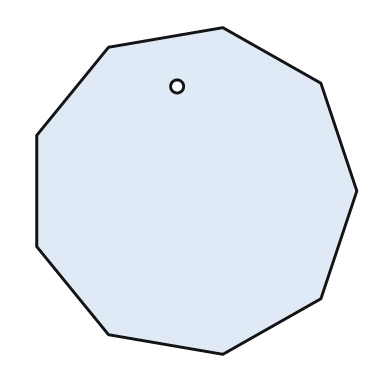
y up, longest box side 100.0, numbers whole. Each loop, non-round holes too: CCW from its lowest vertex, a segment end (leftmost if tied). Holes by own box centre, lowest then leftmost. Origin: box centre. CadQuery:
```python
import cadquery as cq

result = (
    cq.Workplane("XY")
    .moveTo(8.0, -50.0)
    .lineTo(38.0, -33.0)
    .lineTo(49.0, 0.0)
    .lineTo(38.0, 33.0)
    .lineTo(8.0, 50.0)
    .lineTo(-27.0, 44.0)
    .lineTo(-49.0, 17.0)
    .lineTo(-49.0, -17.0)
    .lineTo(-27.0, -44.0)
    .close()
    .moveTo(-6.0, 32.0)
    .circle(2.0)
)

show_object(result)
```